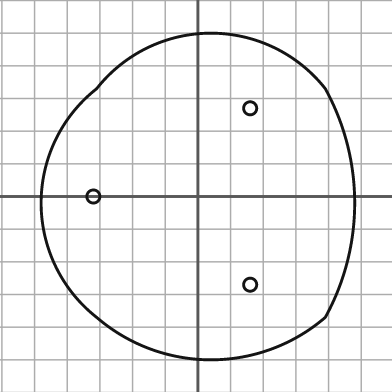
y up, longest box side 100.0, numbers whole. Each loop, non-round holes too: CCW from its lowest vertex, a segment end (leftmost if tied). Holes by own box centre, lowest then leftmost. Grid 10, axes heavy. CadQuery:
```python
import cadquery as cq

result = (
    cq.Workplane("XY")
    .moveTo(-31.0, -37.0)
    .threePointArc((4.0, -50.0), (39.0, -37.0))
    .threePointArc((48.0, -2.0), (39.0, 33.0))
    .threePointArc((4.0, 50.0), (-31.0, 33.0))
    .threePointArc((-48.0, -2.0), (-31.0, -37.0))
    .close()
    .moveTo(16.0, -27.0)
    .circle(2.0)
    .moveTo(-32.0, 0.0)
    .circle(2.0)
    .moveTo(16.0, 27.0)
    .circle(2.0)
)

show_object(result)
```